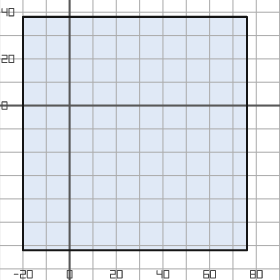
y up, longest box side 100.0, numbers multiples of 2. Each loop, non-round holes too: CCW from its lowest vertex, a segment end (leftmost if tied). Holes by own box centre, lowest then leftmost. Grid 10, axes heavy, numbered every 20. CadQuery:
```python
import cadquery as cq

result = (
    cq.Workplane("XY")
    .moveTo(-20.0, -62.0)
    .lineTo(76.0, -62.0)
    .lineTo(76.0, 38.0)
    .lineTo(-20.0, 38.0)
    .close()
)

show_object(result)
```